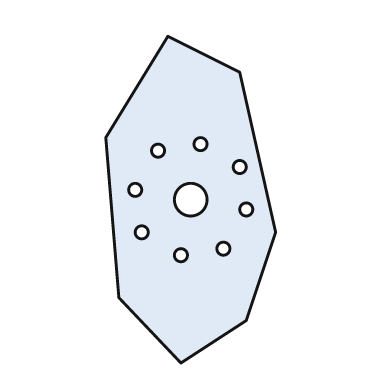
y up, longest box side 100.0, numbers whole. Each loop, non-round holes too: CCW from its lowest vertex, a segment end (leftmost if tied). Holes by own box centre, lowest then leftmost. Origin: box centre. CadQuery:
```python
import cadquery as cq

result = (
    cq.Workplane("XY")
    .moveTo(-3.0, -50.0)
    .lineTo(17.0, -37.0)
    .lineTo(26.0, -10.0)
    .lineTo(15.0, 39.0)
    .lineTo(-7.0, 50.0)
    .lineTo(-26.0, 19.0)
    .lineTo(-22.0, -30.0)
    .close()
    .moveTo(-3.0, -17.0)
    .circle(2.0)
    .moveTo(10.0, -15.0)
    .circle(2.0)
    .moveTo(-15.0, -10.0)
    .circle(2.0)
    .moveTo(17.0, -3.0)
    .circle(2.0)
    .moveTo(0.0, 0.0)
    .circle(5.0)
    .moveTo(-17.0, 3.0)
    .circle(2.0)
    .moveTo(15.0, 10.0)
    .circle(2.0)
    .moveTo(-10.0, 15.0)
    .circle(2.0)
    .moveTo(3.0, 17.0)
    .circle(2.0)
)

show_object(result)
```